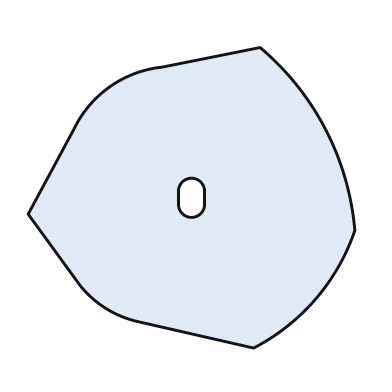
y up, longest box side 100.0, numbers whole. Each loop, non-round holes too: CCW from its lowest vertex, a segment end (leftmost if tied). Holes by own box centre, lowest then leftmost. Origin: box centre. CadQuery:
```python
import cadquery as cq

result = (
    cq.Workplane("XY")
    .moveTo(19.0, -46.0)
    .threePointArc((38.0, -31.0), (50.0, -10.0))
    .threePointArc((41.0, 21.0), (21.0, 46.0))
    .lineTo(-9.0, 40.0)
    .threePointArc((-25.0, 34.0), (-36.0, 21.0))
    .lineTo(-50.0, -5.0)
    .lineTo(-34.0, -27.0)
    .threePointArc((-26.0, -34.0), (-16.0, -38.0))
    .close()
    .moveTo(-4.0, -2.0)
    .threePointArc((0.0, -6.0), (4.0, -2.0))
    .lineTo(4.0, 2.0)
    .threePointArc((0.0, 6.0), (-4.0, 2.0))
    .close()
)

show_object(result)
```